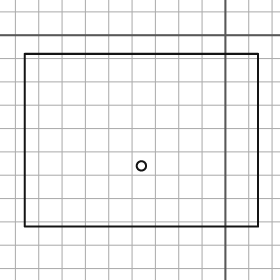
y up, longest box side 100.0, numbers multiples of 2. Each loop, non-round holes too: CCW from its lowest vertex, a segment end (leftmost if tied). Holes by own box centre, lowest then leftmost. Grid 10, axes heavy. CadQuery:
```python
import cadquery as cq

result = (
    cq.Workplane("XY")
    .moveTo(-86.0, -82.0)
    .lineTo(14.0, -82.0)
    .lineTo(14.0, -8.0)
    .lineTo(-86.0, -8.0)
    .close()
    .moveTo(-36.0, -56.0)
    .circle(2.0)
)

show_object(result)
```